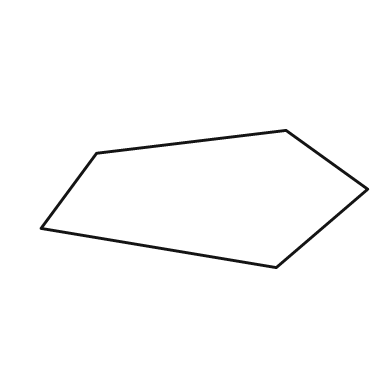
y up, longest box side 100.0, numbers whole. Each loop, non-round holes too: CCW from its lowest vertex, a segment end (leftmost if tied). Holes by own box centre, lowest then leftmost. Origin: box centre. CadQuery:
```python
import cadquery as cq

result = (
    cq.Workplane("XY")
    .moveTo(22.0, -21.0)
    .lineTo(50.0, 3.0)
    .lineTo(25.0, 21.0)
    .lineTo(-33.0, 14.0)
    .lineTo(-50.0, -9.0)
    .close()
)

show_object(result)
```